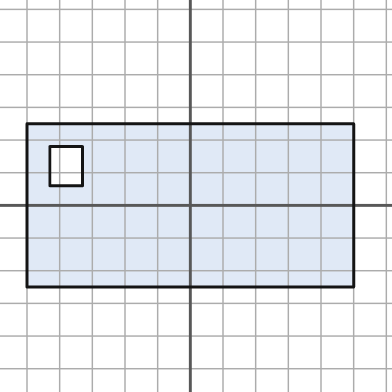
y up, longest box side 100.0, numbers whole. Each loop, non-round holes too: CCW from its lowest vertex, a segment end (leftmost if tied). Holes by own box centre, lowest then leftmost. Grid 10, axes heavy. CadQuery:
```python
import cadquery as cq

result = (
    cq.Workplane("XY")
    .moveTo(-50.0, -25.0)
    .lineTo(50.0, -25.0)
    .lineTo(50.0, 25.0)
    .lineTo(-50.0, 25.0)
    .close()
    .moveTo(-43.0, 6.0)
    .lineTo(-33.0, 6.0)
    .lineTo(-33.0, 18.0)
    .lineTo(-43.0, 18.0)
    .close()
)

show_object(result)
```